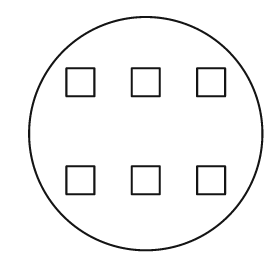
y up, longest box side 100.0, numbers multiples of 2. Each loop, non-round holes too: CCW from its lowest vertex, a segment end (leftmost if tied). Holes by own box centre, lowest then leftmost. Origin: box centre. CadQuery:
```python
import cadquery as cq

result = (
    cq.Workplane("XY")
    .moveTo(0.0, 0.0)
    .circle(50.0)
    .moveTo(-34.0, -26.0)
    .lineTo(-22.0, -26.0)
    .lineTo(-22.0, -14.0)
    .lineTo(-34.0, -14.0)
    .close()
    .moveTo(-6.0, -26.0)
    .lineTo(6.0, -26.0)
    .lineTo(6.0, -14.0)
    .lineTo(-6.0, -14.0)
    .close()
    .moveTo(22.0, -26.0)
    .lineTo(34.0, -26.0)
    .lineTo(34.0, -14.0)
    .lineTo(22.0, -14.0)
    .close()
    .moveTo(-34.0, 16.0)
    .lineTo(-22.0, 16.0)
    .lineTo(-22.0, 28.0)
    .lineTo(-34.0, 28.0)
    .close()
    .moveTo(-6.0, 16.0)
    .lineTo(6.0, 16.0)
    .lineTo(6.0, 28.0)
    .lineTo(-6.0, 28.0)
    .close()
    .moveTo(22.0, 16.0)
    .lineTo(34.0, 16.0)
    .lineTo(34.0, 28.0)
    .lineTo(22.0, 28.0)
    .close()
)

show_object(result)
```